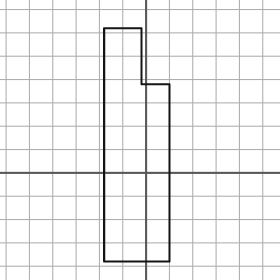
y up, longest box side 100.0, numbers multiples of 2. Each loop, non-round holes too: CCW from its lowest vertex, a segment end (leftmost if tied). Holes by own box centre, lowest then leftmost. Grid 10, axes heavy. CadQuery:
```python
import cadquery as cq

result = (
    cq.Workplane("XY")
    .moveTo(-18.0, -38.0)
    .lineTo(10.0, -38.0)
    .lineTo(10.0, 38.0)
    .lineTo(-2.0, 38.0)
    .lineTo(-2.0, 62.0)
    .lineTo(-18.0, 62.0)
    .close()
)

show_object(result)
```